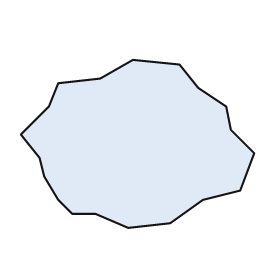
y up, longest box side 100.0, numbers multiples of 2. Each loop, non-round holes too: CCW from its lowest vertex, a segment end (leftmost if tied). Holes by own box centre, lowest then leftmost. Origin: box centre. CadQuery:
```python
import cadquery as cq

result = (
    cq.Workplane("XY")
    .moveTo(-4.0, -36.0)
    .lineTo(14.0, -34.0)
    .lineTo(28.0, -24.0)
    .lineTo(44.0, -20.0)
    .lineTo(50.0, -4.0)
    .lineTo(40.0, 6.0)
    .lineTo(38.0, 16.0)
    .lineTo(26.0, 24.0)
    .lineTo(18.0, 34.0)
    .lineTo(-2.0, 36.0)
    .lineTo(-16.0, 28.0)
    .lineTo(-34.0, 26.0)
    .lineTo(-38.0, 16.0)
    .lineTo(-50.0, 4.0)
    .lineTo(-42.0, -6.0)
    .lineTo(-40.0, -14.0)
    .lineTo(-34.0, -24.0)
    .lineTo(-28.0, -30.0)
    .lineTo(-18.0, -30.0)
    .close()
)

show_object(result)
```